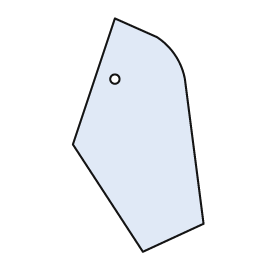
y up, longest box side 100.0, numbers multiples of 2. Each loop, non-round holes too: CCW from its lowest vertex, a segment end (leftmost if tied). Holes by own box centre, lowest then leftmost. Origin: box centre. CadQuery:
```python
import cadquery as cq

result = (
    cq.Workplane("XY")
    .moveTo(2.0, -50.0)
    .lineTo(28.0, -38.0)
    .lineTo(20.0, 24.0)
    .threePointArc((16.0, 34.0), (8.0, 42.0))
    .lineTo(-10.0, 50.0)
    .lineTo(-28.0, -4.0)
    .close()
    .moveTo(-10.0, 24.0)
    .circle(2.0)
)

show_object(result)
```